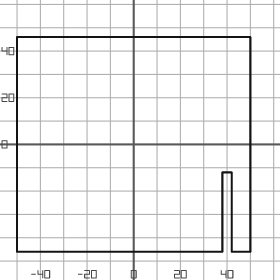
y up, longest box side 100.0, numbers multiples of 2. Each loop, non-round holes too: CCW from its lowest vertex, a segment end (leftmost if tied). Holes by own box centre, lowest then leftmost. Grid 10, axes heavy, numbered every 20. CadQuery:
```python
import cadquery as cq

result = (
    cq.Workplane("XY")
    .moveTo(-50.0, -46.0)
    .lineTo(38.0, -46.0)
    .lineTo(38.0, -12.0)
    .lineTo(42.0, -12.0)
    .lineTo(42.0, -46.0)
    .lineTo(50.0, -46.0)
    .lineTo(50.0, 46.0)
    .lineTo(-50.0, 46.0)
    .close()
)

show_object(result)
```